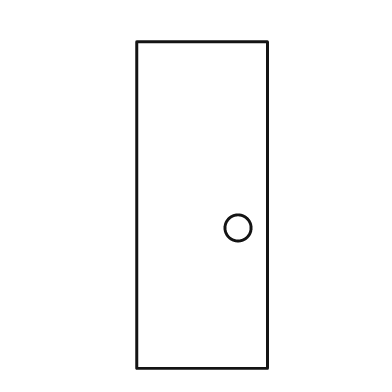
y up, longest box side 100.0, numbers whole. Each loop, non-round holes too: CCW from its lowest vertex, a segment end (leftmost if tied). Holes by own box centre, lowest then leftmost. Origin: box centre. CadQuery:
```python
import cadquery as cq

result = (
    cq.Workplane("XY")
    .moveTo(-20.0, -50.0)
    .lineTo(20.0, -50.0)
    .lineTo(20.0, 50.0)
    .lineTo(-20.0, 50.0)
    .close()
    .moveTo(11.0, -7.0)
    .circle(4.0)
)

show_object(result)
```